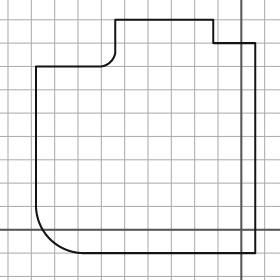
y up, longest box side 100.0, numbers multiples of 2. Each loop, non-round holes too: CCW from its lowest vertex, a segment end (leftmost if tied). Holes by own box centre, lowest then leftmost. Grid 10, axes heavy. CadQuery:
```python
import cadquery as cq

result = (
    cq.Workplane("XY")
    .moveTo(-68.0, -10.0)
    .lineTo(6.0, -10.0)
    .lineTo(6.0, 80.0)
    .lineTo(-12.0, 80.0)
    .lineTo(-12.0, 90.0)
    .lineTo(-54.0, 90.0)
    .lineTo(-54.0, 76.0)
    .threePointArc((-56.0, 72.0), (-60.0, 70.0))
    .lineTo(-88.0, 70.0)
    .lineTo(-88.0, 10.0)
    .threePointArc((-82.0, -4.0), (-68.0, -10.0))
    .close()
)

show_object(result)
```